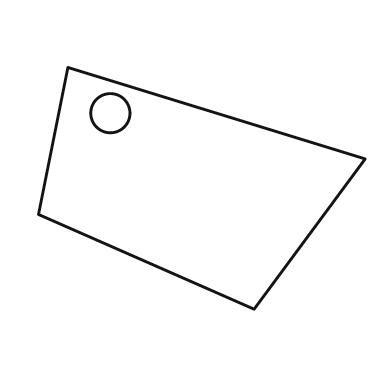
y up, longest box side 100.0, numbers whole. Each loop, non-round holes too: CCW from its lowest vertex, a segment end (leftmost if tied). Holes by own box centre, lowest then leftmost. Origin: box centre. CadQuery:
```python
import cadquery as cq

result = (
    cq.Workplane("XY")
    .moveTo(16.0, -37.0)
    .lineTo(50.0, 9.0)
    .lineTo(-41.0, 37.0)
    .lineTo(-50.0, -8.0)
    .close()
    .moveTo(-28.0, 23.0)
    .circle(6.0)
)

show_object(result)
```